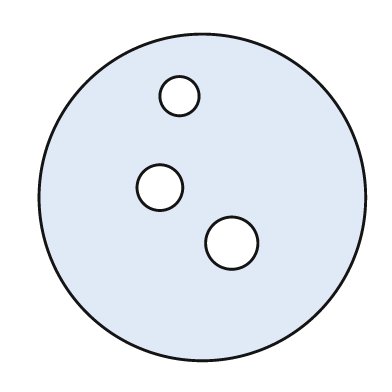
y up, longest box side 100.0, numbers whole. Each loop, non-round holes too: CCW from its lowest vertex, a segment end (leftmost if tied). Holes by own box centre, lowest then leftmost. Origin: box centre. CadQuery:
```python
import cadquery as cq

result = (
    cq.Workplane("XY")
    .moveTo(0.0, 0.0)
    .circle(50.0)
    .moveTo(9.0, -14.0)
    .circle(8.0)
    .moveTo(-13.0, 3.0)
    .circle(7.0)
    .moveTo(-7.0, 31.0)
    .circle(6.0)
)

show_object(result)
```